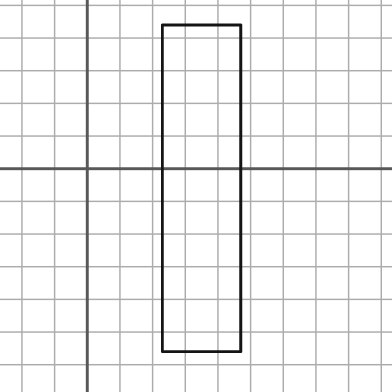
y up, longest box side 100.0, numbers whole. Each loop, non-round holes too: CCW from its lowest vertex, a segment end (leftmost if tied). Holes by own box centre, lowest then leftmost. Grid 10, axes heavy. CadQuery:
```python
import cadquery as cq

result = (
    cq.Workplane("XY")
    .moveTo(23.0, -56.0)
    .lineTo(47.0, -56.0)
    .lineTo(47.0, 44.0)
    .lineTo(23.0, 44.0)
    .close()
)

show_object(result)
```